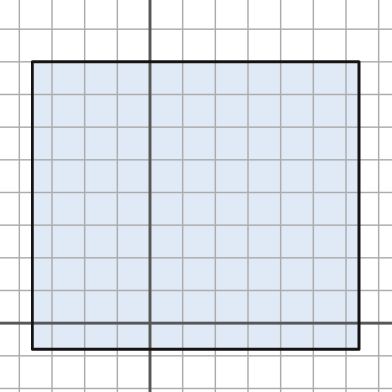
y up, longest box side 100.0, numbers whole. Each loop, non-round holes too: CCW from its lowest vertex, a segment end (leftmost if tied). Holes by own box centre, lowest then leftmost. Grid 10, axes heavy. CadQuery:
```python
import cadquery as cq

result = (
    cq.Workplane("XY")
    .moveTo(-36.0, -8.0)
    .lineTo(64.0, -8.0)
    .lineTo(64.0, 80.0)
    .lineTo(-36.0, 80.0)
    .close()
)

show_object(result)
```